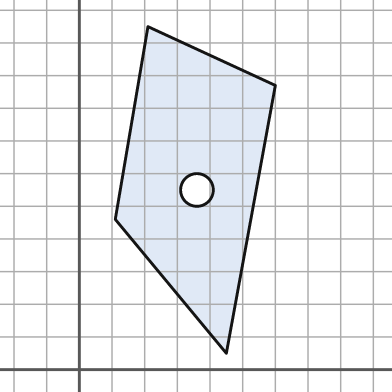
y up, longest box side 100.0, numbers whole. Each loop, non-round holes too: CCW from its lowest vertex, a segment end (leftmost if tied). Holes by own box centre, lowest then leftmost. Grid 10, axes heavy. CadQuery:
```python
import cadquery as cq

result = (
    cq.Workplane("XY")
    .moveTo(45.0, 5.0)
    .lineTo(60.0, 87.0)
    .lineTo(21.0, 105.0)
    .lineTo(11.0, 46.0)
    .close()
    .moveTo(36.0, 55.0)
    .circle(5.0)
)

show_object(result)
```